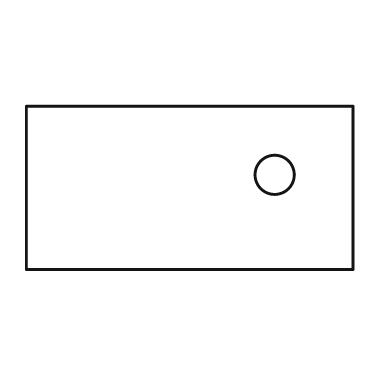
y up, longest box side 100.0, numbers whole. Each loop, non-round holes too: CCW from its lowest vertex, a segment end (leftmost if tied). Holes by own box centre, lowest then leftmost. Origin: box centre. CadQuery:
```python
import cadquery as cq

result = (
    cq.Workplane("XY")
    .moveTo(-50.0, -25.0)
    .lineTo(50.0, -25.0)
    .lineTo(50.0, 25.0)
    .lineTo(-50.0, 25.0)
    .close()
    .moveTo(26.0, 4.0)
    .circle(6.0)
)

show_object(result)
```